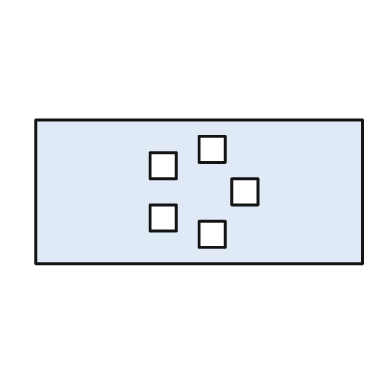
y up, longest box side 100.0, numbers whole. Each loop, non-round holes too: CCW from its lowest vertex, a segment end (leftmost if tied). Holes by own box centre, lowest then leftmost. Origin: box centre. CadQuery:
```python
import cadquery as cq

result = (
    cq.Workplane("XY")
    .moveTo(-50.0, -22.0)
    .lineTo(50.0, -22.0)
    .lineTo(50.0, 22.0)
    .lineTo(-50.0, 22.0)
    .close()
    .moveTo(0.0, -17.0)
    .lineTo(8.0, -17.0)
    .lineTo(8.0, -9.0)
    .lineTo(0.0, -9.0)
    .close()
    .moveTo(-15.0, -12.0)
    .lineTo(-7.0, -12.0)
    .lineTo(-7.0, -4.0)
    .lineTo(-15.0, -4.0)
    .close()
    .moveTo(10.0, -4.0)
    .lineTo(18.0, -4.0)
    .lineTo(18.0, 4.0)
    .lineTo(10.0, 4.0)
    .close()
    .moveTo(-15.0, 4.0)
    .lineTo(-7.0, 4.0)
    .lineTo(-7.0, 12.0)
    .lineTo(-15.0, 12.0)
    .close()
    .moveTo(0.0, 9.0)
    .lineTo(8.0, 9.0)
    .lineTo(8.0, 17.0)
    .lineTo(0.0, 17.0)
    .close()
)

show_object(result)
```